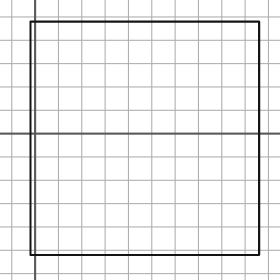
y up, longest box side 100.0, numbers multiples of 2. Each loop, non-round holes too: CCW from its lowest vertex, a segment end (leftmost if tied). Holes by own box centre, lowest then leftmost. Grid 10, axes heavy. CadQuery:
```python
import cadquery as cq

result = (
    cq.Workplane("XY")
    .moveTo(-2.0, -52.0)
    .lineTo(96.0, -52.0)
    .lineTo(96.0, 48.0)
    .lineTo(-2.0, 48.0)
    .close()
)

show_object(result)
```